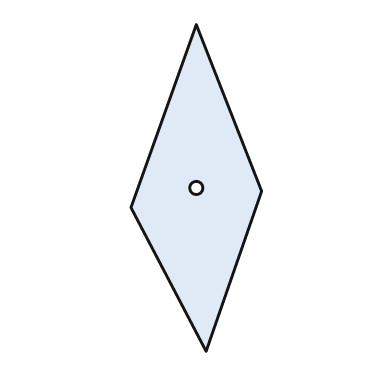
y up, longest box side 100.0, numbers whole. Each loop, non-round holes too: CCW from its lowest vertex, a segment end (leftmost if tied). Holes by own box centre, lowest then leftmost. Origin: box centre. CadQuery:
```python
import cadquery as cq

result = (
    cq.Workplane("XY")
    .moveTo(3.0, -50.0)
    .lineTo(20.0, -1.0)
    .lineTo(0.0, 50.0)
    .lineTo(-20.0, -6.0)
    .close()
    .moveTo(0.0, 0.0)
    .circle(2.0)
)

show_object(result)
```